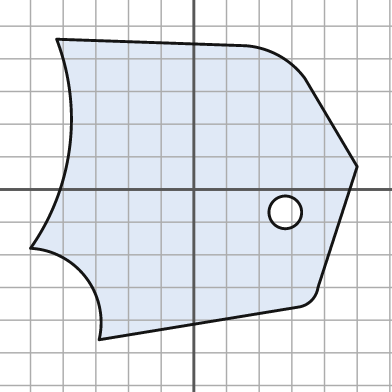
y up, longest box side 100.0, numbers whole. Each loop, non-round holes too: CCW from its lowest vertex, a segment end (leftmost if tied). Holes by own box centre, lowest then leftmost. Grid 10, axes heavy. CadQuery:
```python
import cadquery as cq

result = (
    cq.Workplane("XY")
    .moveTo(-29.0, -46.0)
    .lineTo(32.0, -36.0)
    .threePointArc((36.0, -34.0), (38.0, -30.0))
    .lineTo(50.0, 7.0)
    .lineTo(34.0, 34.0)
    .threePointArc((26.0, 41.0), (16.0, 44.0))
    .lineTo(-42.0, 46.0)
    .threePointArc((-38.0, 13.0), (-50.0, -18.0))
    .threePointArc((-33.0, -27.0), (-29.0, -46.0))
    .close()
    .moveTo(28.0, -7.0)
    .circle(5.0)
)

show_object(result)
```